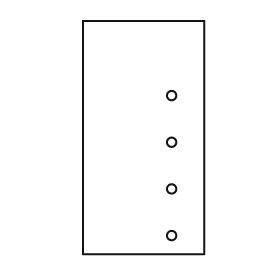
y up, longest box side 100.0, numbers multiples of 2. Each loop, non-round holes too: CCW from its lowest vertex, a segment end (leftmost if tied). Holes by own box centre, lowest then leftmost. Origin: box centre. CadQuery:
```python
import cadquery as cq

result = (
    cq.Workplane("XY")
    .moveTo(-26.0, -50.0)
    .lineTo(26.0, -50.0)
    .lineTo(26.0, 50.0)
    .lineTo(-26.0, 50.0)
    .close()
    .moveTo(12.0, -42.0)
    .circle(2.0)
    .moveTo(12.0, -22.0)
    .circle(2.0)
    .moveTo(12.0, -2.0)
    .circle(2.0)
    .moveTo(12.0, 18.0)
    .circle(2.0)
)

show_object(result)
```